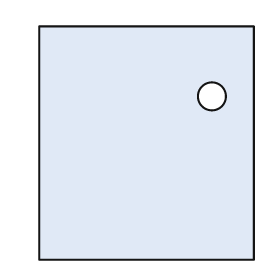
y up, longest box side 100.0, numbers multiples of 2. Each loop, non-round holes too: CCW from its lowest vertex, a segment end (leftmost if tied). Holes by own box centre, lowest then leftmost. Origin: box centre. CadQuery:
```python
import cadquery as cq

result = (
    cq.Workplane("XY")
    .moveTo(-46.0, -50.0)
    .lineTo(46.0, -50.0)
    .lineTo(46.0, 50.0)
    .lineTo(-46.0, 50.0)
    .close()
    .moveTo(28.0, 20.0)
    .circle(6.0)
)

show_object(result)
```